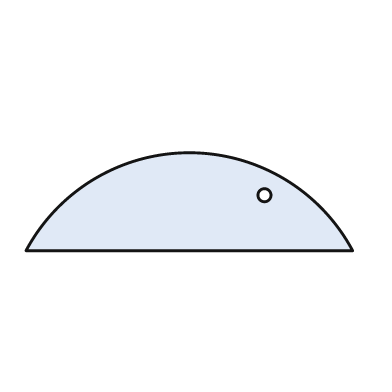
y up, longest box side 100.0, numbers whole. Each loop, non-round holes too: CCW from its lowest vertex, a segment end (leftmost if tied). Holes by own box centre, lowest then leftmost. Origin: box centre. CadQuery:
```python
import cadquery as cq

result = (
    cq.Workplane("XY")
    .moveTo(-50.0, -15.0)
    .lineTo(50.0, -15.0)
    .threePointArc((0.0, 15.0), (-50.0, -15.0))
    .close()
    .moveTo(23.0, 2.0)
    .circle(2.0)
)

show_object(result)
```